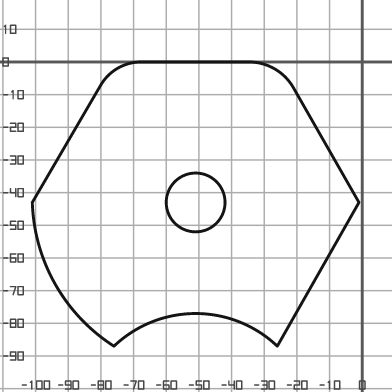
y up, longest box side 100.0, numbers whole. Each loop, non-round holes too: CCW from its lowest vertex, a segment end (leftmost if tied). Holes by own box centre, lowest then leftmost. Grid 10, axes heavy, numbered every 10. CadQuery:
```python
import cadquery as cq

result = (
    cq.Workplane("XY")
    .moveTo(-76.0, -87.0)
    .threePointArc((-51.0, -77.0), (-26.0, -87.0))
    .lineTo(-1.0, -43.0)
    .lineTo(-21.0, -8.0)
    .threePointArc((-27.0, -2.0), (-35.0, 0.0))
    .lineTo(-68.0, 0.0)
    .threePointArc((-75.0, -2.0), (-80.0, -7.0))
    .lineTo(-101.0, -43.0)
    .threePointArc((-94.0, -68.0), (-76.0, -87.0))
    .close()
    .moveTo(-51.0, -43.0)
    .circle(9.0)
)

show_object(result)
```